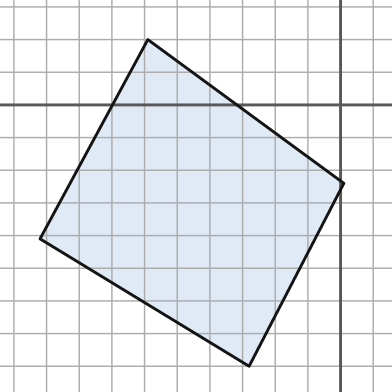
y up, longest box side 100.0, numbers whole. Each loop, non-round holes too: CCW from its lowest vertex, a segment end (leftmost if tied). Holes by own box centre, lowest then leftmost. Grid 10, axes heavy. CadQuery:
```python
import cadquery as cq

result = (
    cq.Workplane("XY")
    .moveTo(-28.0, -80.0)
    .lineTo(1.0, -24.0)
    .lineTo(-59.0, 20.0)
    .lineTo(-92.0, -41.0)
    .close()
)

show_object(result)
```